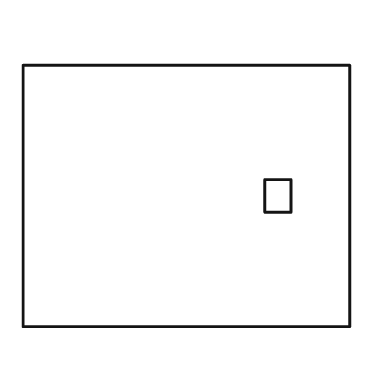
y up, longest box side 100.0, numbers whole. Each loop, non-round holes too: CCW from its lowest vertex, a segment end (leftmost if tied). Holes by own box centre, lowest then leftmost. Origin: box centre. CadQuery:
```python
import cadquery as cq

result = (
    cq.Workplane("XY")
    .moveTo(-50.0, -40.0)
    .lineTo(50.0, -40.0)
    .lineTo(50.0, 40.0)
    .lineTo(-50.0, 40.0)
    .close()
    .moveTo(24.0, -5.0)
    .lineTo(32.0, -5.0)
    .lineTo(32.0, 5.0)
    .lineTo(24.0, 5.0)
    .close()
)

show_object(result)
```